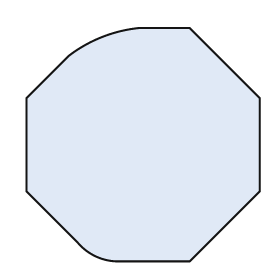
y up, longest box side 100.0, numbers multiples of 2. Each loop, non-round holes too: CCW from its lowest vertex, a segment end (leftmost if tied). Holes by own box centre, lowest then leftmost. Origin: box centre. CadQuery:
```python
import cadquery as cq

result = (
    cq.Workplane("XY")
    .moveTo(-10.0, -50.0)
    .lineTo(20.0, -50.0)
    .lineTo(50.0, -20.0)
    .lineTo(50.0, 20.0)
    .lineTo(20.0, 50.0)
    .lineTo(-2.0, 50.0)
    .threePointArc((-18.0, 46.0), (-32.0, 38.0))
    .lineTo(-50.0, 20.0)
    .lineTo(-50.0, -20.0)
    .lineTo(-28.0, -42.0)
    .threePointArc((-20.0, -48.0), (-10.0, -50.0))
    .close()
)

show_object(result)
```